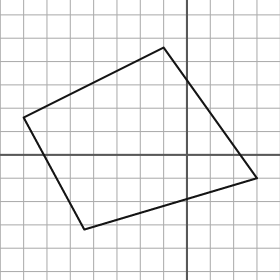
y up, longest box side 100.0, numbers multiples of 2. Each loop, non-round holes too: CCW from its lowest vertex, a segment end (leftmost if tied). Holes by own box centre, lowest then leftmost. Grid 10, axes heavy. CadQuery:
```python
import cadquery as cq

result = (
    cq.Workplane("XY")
    .moveTo(-44.0, -32.0)
    .lineTo(30.0, -10.0)
    .lineTo(-10.0, 46.0)
    .lineTo(-70.0, 16.0)
    .close()
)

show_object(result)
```